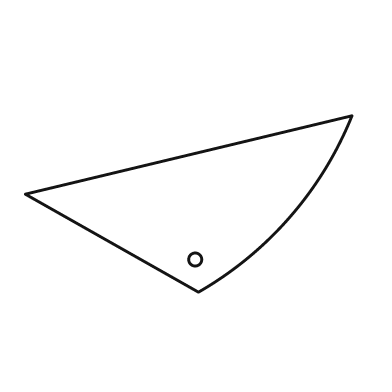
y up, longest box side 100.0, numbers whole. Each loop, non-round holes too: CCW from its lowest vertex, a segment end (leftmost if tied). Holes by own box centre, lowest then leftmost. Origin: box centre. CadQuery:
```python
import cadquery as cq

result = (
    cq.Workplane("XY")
    .moveTo(3.0, -27.0)
    .threePointArc((31.0, -4.0), (50.0, 27.0))
    .lineTo(-50.0, 3.0)
    .close()
    .moveTo(2.0, -17.0)
    .circle(2.0)
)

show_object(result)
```